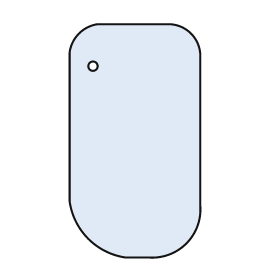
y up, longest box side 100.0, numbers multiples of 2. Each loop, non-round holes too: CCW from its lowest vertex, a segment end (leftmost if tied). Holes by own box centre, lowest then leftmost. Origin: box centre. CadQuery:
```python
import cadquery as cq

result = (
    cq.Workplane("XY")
    .moveTo(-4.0, -50.0)
    .lineTo(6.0, -50.0)
    .threePointArc((22.0, -44.0), (28.0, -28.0))
    .lineTo(28.0, 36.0)
    .threePointArc((24.0, 46.0), (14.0, 50.0))
    .lineTo(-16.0, 50.0)
    .threePointArc((-24.0, 46.0), (-28.0, 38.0))
    .lineTo(-28.0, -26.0)
    .threePointArc((-20.0, -42.0), (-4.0, -50.0))
    .close()
    .moveTo(-18.0, 32.0)
    .circle(2.0)
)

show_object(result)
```